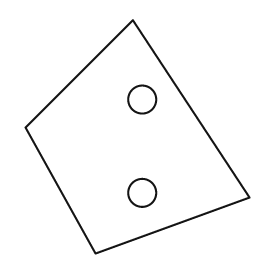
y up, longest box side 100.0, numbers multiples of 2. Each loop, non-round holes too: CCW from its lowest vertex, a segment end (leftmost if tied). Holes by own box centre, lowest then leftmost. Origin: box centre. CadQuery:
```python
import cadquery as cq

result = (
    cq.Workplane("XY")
    .moveTo(-18.0, -50.0)
    .lineTo(48.0, -26.0)
    .lineTo(-2.0, 50.0)
    .lineTo(-48.0, 4.0)
    .close()
    .moveTo(2.0, -24.0)
    .circle(6.0)
    .moveTo(2.0, 16.0)
    .circle(6.0)
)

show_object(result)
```